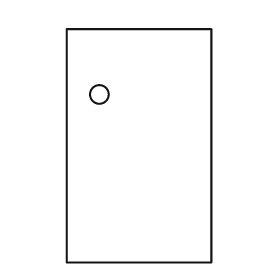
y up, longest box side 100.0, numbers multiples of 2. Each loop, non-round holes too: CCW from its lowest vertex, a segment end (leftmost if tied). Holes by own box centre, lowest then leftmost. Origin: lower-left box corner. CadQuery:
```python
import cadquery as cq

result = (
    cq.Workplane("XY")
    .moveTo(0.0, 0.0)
    .lineTo(62.0, 0.0)
    .lineTo(62.0, 100.0)
    .lineTo(0.0, 100.0)
    .close()
    .moveTo(14.0, 72.0)
    .circle(4.0)
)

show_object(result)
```